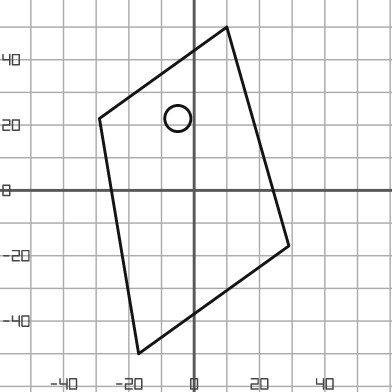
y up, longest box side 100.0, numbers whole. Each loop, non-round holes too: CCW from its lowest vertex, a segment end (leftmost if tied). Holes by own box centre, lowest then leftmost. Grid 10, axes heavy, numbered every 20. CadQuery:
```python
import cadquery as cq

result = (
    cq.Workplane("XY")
    .moveTo(-17.0, -50.0)
    .lineTo(29.0, -17.0)
    .lineTo(10.0, 50.0)
    .lineTo(-29.0, 22.0)
    .close()
    .moveTo(-5.0, 22.0)
    .circle(4.0)
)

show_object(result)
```